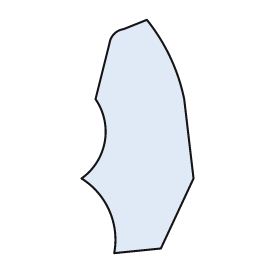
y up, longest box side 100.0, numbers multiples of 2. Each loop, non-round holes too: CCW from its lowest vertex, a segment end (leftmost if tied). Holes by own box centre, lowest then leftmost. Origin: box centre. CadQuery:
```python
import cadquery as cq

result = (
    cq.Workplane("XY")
    .moveTo(-10.0, -50.0)
    .lineTo(10.0, -48.0)
    .lineTo(24.0, -18.0)
    .lineTo(20.0, 16.0)
    .threePointArc((14.0, 34.0), (4.0, 50.0))
    .lineTo(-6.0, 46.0)
    .threePointArc((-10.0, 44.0), (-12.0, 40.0))
    .lineTo(-18.0, 16.0)
    .threePointArc((-14.0, -2.0), (-24.0, -18.0))
    .threePointArc((-12.0, -32.0), (-10.0, -50.0))
    .close()
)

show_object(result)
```